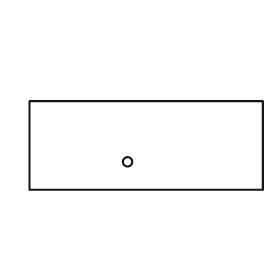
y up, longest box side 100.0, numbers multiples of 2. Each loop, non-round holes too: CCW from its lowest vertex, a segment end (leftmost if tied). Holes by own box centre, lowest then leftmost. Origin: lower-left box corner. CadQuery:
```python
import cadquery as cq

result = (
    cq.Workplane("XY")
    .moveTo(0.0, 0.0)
    .lineTo(100.0, 0.0)
    .lineTo(100.0, 38.0)
    .lineTo(0.0, 38.0)
    .close()
    .moveTo(42.0, 12.0)
    .circle(2.0)
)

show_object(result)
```